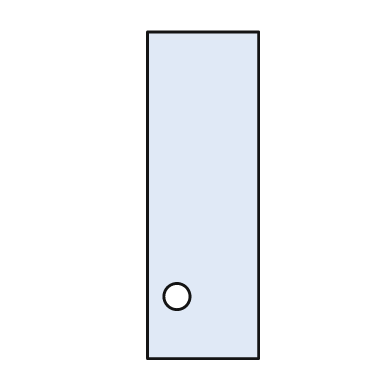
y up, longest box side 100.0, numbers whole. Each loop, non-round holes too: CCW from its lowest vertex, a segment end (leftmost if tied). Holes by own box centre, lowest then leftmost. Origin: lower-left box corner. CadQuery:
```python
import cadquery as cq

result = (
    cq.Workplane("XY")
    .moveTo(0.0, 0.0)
    .lineTo(34.0, 0.0)
    .lineTo(34.0, 100.0)
    .lineTo(0.0, 100.0)
    .close()
    .moveTo(9.0, 19.0)
    .circle(4.0)
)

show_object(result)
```